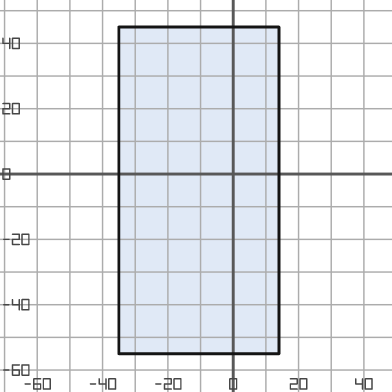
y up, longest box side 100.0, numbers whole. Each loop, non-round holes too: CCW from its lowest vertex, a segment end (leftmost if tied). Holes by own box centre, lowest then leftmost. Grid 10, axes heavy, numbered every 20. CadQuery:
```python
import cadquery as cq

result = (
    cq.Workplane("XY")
    .moveTo(-35.0, -55.0)
    .lineTo(14.0, -55.0)
    .lineTo(14.0, 45.0)
    .lineTo(-35.0, 45.0)
    .close()
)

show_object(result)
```